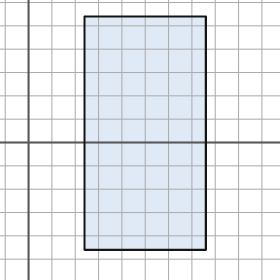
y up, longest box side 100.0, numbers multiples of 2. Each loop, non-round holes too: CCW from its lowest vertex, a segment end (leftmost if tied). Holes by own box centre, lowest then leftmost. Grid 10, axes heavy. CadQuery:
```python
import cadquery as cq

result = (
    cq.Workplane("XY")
    .moveTo(24.0, -46.0)
    .lineTo(76.0, -46.0)
    .lineTo(76.0, 54.0)
    .lineTo(24.0, 54.0)
    .close()
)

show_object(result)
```